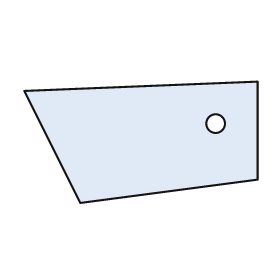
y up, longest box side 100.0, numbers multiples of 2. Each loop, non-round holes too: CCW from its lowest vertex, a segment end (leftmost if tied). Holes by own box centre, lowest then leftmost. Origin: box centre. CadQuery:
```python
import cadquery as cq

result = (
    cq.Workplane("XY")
    .moveTo(-26.0, -26.0)
    .lineTo(50.0, -16.0)
    .lineTo(50.0, 26.0)
    .lineTo(-50.0, 22.0)
    .close()
    .moveTo(32.0, 8.0)
    .circle(4.0)
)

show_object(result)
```